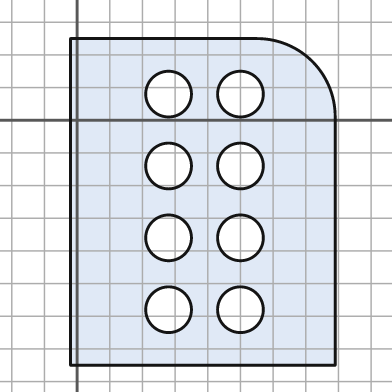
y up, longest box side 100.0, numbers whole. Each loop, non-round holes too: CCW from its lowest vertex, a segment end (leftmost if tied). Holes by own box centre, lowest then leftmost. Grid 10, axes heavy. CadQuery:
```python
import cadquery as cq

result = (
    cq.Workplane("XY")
    .moveTo(-2.0, -75.0)
    .lineTo(79.0, -75.0)
    .lineTo(79.0, 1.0)
    .threePointArc((72.0, 18.0), (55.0, 25.0))
    .lineTo(-2.0, 25.0)
    .close()
    .moveTo(28.0, -58.0)
    .circle(7.0)
    .moveTo(50.0, -58.0)
    .circle(7.0)
    .moveTo(28.0, -36.0)
    .circle(7.0)
    .moveTo(50.0, -36.0)
    .circle(7.0)
    .moveTo(28.0, -14.0)
    .circle(7.0)
    .moveTo(50.0, -14.0)
    .circle(7.0)
    .moveTo(28.0, 8.0)
    .circle(7.0)
    .moveTo(50.0, 8.0)
    .circle(7.0)
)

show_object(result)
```